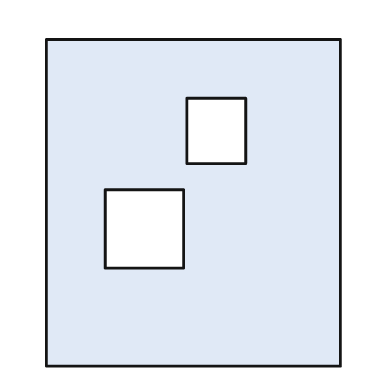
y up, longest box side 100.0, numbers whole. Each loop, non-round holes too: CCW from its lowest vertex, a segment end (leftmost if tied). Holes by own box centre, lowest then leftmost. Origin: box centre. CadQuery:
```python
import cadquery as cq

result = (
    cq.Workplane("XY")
    .moveTo(-45.0, -50.0)
    .lineTo(45.0, -50.0)
    .lineTo(45.0, 50.0)
    .lineTo(-45.0, 50.0)
    .close()
    .moveTo(-27.0, -20.0)
    .lineTo(-3.0, -20.0)
    .lineTo(-3.0, 4.0)
    .lineTo(-27.0, 4.0)
    .close()
    .moveTo(-2.0, 12.0)
    .lineTo(16.0, 12.0)
    .lineTo(16.0, 32.0)
    .lineTo(-2.0, 32.0)
    .close()
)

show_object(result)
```